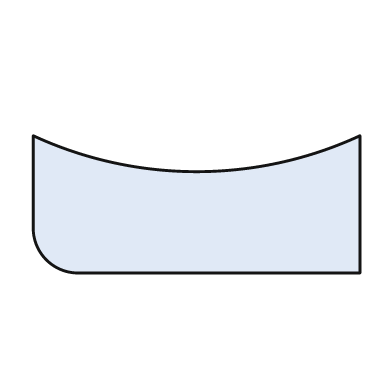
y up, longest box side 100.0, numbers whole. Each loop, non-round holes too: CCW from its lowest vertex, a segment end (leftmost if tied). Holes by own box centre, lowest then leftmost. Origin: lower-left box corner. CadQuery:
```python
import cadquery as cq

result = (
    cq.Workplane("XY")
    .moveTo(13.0, 0.0)
    .lineTo(100.0, 0.0)
    .lineTo(100.0, 42.0)
    .threePointArc((50.0, 31.0), (0.0, 42.0))
    .lineTo(0.0, 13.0)
    .threePointArc((4.0, 4.0), (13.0, 0.0))
    .close()
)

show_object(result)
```